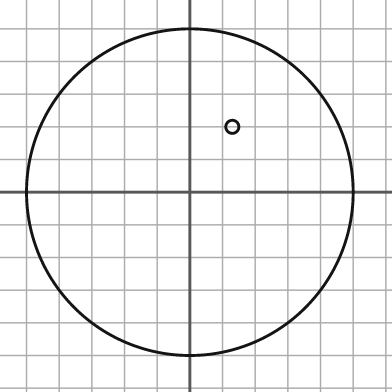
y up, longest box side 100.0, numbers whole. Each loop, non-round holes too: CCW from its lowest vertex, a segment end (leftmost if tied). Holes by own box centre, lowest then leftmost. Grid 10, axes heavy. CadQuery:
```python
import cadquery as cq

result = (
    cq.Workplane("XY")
    .moveTo(0.0, 0.0)
    .circle(50.0)
    .moveTo(13.0, 20.0)
    .circle(2.0)
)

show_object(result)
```